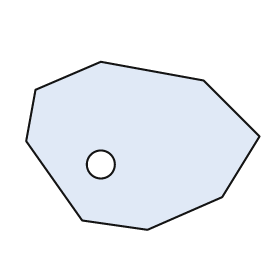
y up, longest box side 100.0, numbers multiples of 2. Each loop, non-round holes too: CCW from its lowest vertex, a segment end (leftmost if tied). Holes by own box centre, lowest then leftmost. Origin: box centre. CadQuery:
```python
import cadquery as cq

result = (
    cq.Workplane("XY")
    .moveTo(2.0, -36.0)
    .lineTo(34.0, -22.0)
    .lineTo(50.0, 4.0)
    .lineTo(26.0, 28.0)
    .lineTo(-18.0, 36.0)
    .lineTo(-46.0, 24.0)
    .lineTo(-50.0, 2.0)
    .lineTo(-26.0, -32.0)
    .close()
    .moveTo(-18.0, -8.0)
    .circle(6.0)
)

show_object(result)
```